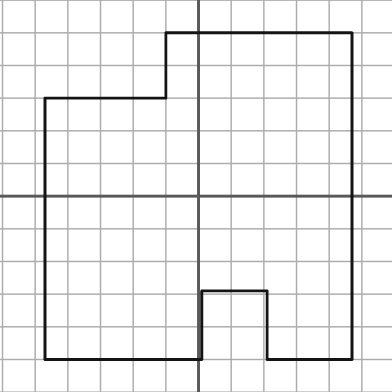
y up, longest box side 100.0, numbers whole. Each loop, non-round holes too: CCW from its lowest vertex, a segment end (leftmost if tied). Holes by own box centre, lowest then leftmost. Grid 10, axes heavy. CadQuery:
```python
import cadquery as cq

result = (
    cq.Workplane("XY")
    .moveTo(-47.0, -50.0)
    .lineTo(1.0, -50.0)
    .lineTo(1.0, -29.0)
    .lineTo(21.0, -29.0)
    .lineTo(21.0, -50.0)
    .lineTo(47.0, -50.0)
    .lineTo(47.0, 50.0)
    .lineTo(-10.0, 50.0)
    .lineTo(-10.0, 30.0)
    .lineTo(-47.0, 30.0)
    .close()
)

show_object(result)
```